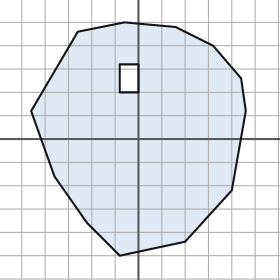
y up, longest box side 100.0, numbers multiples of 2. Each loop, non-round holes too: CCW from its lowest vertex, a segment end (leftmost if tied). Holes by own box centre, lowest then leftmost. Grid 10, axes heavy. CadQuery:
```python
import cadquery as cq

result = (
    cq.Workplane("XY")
    .moveTo(-8.0, -50.0)
    .lineTo(20.0, -44.0)
    .lineTo(40.0, -22.0)
    .lineTo(46.0, 12.0)
    .lineTo(44.0, 26.0)
    .lineTo(32.0, 40.0)
    .lineTo(16.0, 48.0)
    .lineTo(-6.0, 50.0)
    .lineTo(-26.0, 46.0)
    .lineTo(-46.0, 12.0)
    .lineTo(-36.0, -16.0)
    .lineTo(-22.0, -36.0)
    .close()
    .moveTo(-8.0, 20.0)
    .lineTo(0.0, 20.0)
    .lineTo(0.0, 32.0)
    .lineTo(-8.0, 32.0)
    .close()
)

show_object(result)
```